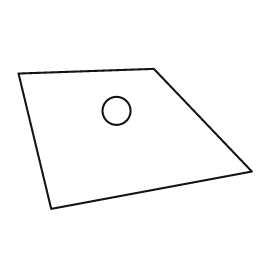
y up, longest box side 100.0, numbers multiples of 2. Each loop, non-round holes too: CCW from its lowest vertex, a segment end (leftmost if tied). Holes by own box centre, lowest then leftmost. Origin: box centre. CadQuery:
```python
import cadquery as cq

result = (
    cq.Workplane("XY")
    .moveTo(-36.0, -30.0)
    .lineTo(50.0, -14.0)
    .lineTo(8.0, 30.0)
    .lineTo(-50.0, 28.0)
    .close()
    .moveTo(-8.0, 12.0)
    .circle(6.0)
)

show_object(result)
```